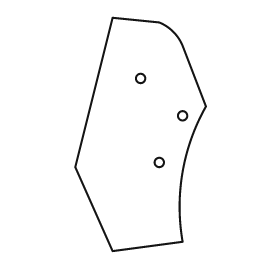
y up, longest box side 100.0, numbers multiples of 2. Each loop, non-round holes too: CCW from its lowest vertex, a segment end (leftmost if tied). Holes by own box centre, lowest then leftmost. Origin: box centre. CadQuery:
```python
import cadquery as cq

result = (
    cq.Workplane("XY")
    .moveTo(-12.0, -50.0)
    .lineTo(18.0, -46.0)
    .threePointArc((18.0, -16.0), (28.0, 12.0))
    .lineTo(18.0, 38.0)
    .threePointArc((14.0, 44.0), (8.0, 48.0))
    .lineTo(-12.0, 50.0)
    .lineTo(-28.0, -14.0)
    .close()
    .moveTo(8.0, -12.0)
    .circle(2.0)
    .moveTo(18.0, 8.0)
    .circle(2.0)
    .moveTo(0.0, 24.0)
    .circle(2.0)
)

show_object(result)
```